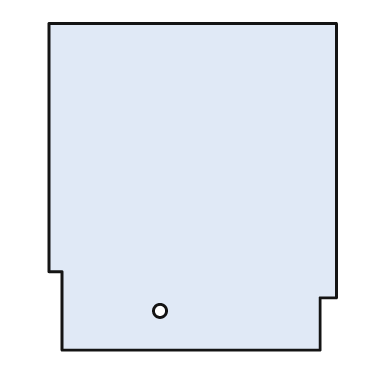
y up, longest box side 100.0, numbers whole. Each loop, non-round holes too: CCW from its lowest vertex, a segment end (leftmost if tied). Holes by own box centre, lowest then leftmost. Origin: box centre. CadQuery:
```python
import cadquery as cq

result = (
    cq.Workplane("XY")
    .moveTo(-40.0, -50.0)
    .lineTo(39.0, -50.0)
    .lineTo(39.0, -34.0)
    .lineTo(44.0, -34.0)
    .lineTo(44.0, 50.0)
    .lineTo(-44.0, 50.0)
    .lineTo(-44.0, -26.0)
    .lineTo(-40.0, -26.0)
    .close()
    .moveTo(-10.0, -38.0)
    .circle(2.0)
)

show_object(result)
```